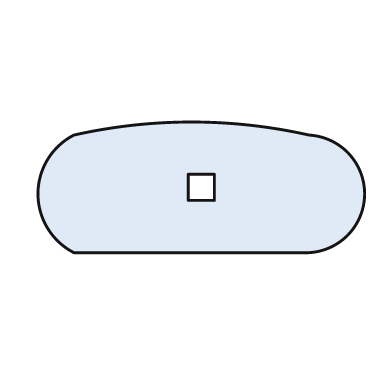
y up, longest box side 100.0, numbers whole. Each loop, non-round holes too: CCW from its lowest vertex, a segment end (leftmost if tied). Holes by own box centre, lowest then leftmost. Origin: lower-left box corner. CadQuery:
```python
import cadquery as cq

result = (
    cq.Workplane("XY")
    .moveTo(11.0, 0.0)
    .lineTo(83.0, 0.0)
    .threePointArc((100.0, 18.0), (83.0, 36.0))
    .threePointArc((47.0, 40.0), (11.0, 36.0))
    .threePointArc((0.0, 18.0), (11.0, 0.0))
    .close()
    .moveTo(46.0, 16.0)
    .lineTo(54.0, 16.0)
    .lineTo(54.0, 24.0)
    .lineTo(46.0, 24.0)
    .close()
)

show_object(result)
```